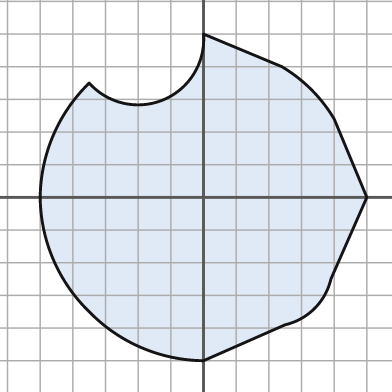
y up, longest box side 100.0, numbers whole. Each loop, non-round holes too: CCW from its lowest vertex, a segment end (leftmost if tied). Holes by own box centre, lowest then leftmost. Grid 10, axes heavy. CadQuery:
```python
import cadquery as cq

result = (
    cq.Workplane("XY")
    .moveTo(0.0, -50.0)
    .lineTo(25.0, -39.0)
    .threePointArc((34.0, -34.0), (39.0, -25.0))
    .lineTo(50.0, 0.0)
    .lineTo(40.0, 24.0)
    .threePointArc((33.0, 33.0), (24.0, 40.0))
    .lineTo(0.0, 50.0)
    .threePointArc((-12.0, 30.0), (-35.0, 35.0))
    .threePointArc((-46.0, 19.0), (-50.0, 0.0))
    .threePointArc((-46.0, -19.0), (-35.0, -35.0))
    .threePointArc((-19.0, -46.0), (0.0, -50.0))
    .close()
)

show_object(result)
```